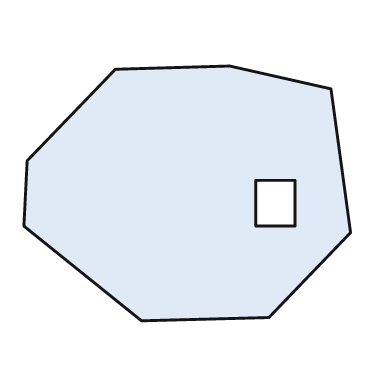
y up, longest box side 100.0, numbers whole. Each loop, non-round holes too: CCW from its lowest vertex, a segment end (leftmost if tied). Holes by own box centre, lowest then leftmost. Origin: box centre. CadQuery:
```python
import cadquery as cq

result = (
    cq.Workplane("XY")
    .moveTo(-14.0, -39.0)
    .lineTo(25.0, -38.0)
    .lineTo(50.0, -12.0)
    .lineTo(44.0, 32.0)
    .lineTo(13.0, 39.0)
    .lineTo(-22.0, 38.0)
    .lineTo(-49.0, 10.0)
    .lineTo(-50.0, -10.0)
    .close()
    .moveTo(21.0, -10.0)
    .lineTo(33.0, -10.0)
    .lineTo(33.0, 4.0)
    .lineTo(21.0, 4.0)
    .close()
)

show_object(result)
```